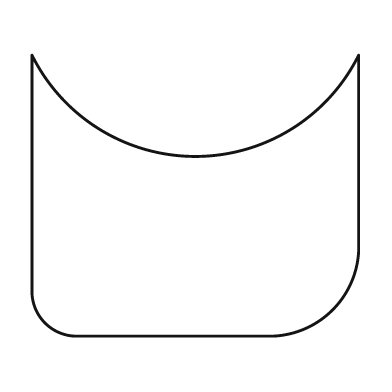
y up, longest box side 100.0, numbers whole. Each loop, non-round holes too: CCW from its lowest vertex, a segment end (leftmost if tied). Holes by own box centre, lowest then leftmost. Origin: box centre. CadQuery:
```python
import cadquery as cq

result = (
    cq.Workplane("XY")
    .moveTo(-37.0, -43.0)
    .lineTo(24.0, -43.0)
    .threePointArc((42.0, -35.0), (50.0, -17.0))
    .lineTo(50.0, 43.0)
    .threePointArc((0.0, 12.0), (-50.0, 43.0))
    .lineTo(-50.0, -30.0)
    .threePointArc((-46.0, -39.0), (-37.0, -43.0))
    .close()
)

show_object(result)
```